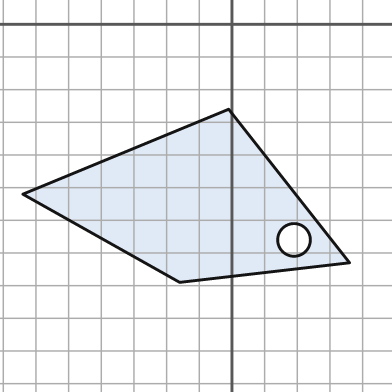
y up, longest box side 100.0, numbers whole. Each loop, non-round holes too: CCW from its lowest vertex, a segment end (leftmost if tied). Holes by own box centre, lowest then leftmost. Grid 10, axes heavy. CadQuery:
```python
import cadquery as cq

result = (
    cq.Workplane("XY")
    .moveTo(-16.0, -79.0)
    .lineTo(36.0, -73.0)
    .lineTo(-1.0, -26.0)
    .lineTo(-64.0, -52.0)
    .close()
    .moveTo(19.0, -66.0)
    .circle(5.0)
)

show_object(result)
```